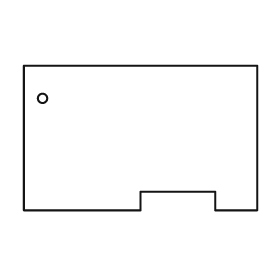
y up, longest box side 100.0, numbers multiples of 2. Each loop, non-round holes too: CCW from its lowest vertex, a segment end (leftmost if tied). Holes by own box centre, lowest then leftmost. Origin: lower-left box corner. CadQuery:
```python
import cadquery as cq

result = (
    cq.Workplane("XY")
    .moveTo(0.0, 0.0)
    .lineTo(50.0, 0.0)
    .lineTo(50.0, 8.0)
    .lineTo(82.0, 8.0)
    .lineTo(82.0, 0.0)
    .lineTo(100.0, 0.0)
    .lineTo(100.0, 62.0)
    .lineTo(0.0, 62.0)
    .close()
    .moveTo(8.0, 48.0)
    .circle(2.0)
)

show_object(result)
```